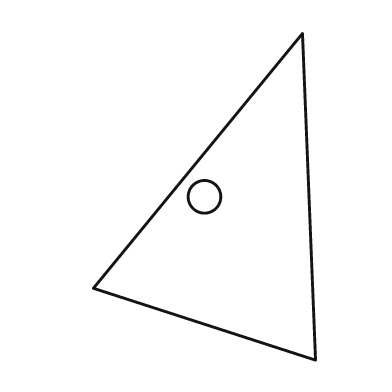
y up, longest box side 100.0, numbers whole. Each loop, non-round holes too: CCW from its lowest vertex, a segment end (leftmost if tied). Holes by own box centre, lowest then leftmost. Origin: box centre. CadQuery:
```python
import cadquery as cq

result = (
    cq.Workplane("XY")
    .moveTo(34.0, -50.0)
    .lineTo(30.0, 50.0)
    .lineTo(-34.0, -28.0)
    .close()
    .moveTo(0.0, 0.0)
    .circle(5.0)
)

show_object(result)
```